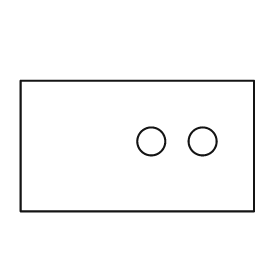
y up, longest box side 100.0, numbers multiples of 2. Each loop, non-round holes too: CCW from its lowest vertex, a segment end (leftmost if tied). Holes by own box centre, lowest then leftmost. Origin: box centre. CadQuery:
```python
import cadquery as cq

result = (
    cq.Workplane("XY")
    .moveTo(-50.0, -28.0)
    .lineTo(50.0, -28.0)
    .lineTo(50.0, 28.0)
    .lineTo(-50.0, 28.0)
    .close()
    .moveTo(6.0, 2.0)
    .circle(6.0)
    .moveTo(28.0, 2.0)
    .circle(6.0)
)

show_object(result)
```